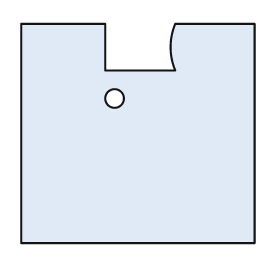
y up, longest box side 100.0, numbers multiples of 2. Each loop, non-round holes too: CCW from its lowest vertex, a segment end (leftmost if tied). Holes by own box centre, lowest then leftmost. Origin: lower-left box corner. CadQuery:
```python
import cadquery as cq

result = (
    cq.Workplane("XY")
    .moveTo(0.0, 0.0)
    .lineTo(100.0, 0.0)
    .lineTo(100.0, 94.0)
    .lineTo(66.0, 94.0)
    .threePointArc((64.0, 84.0), (66.0, 74.0))
    .lineTo(36.0, 74.0)
    .lineTo(36.0, 94.0)
    .lineTo(0.0, 94.0)
    .close()
    .moveTo(40.0, 62.0)
    .circle(4.0)
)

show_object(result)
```